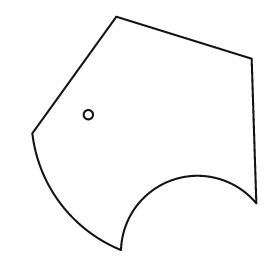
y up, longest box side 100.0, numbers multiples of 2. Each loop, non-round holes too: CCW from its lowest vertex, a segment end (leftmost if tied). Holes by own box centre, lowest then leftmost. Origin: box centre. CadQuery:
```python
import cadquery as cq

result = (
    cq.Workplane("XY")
    .moveTo(-10.0, -50.0)
    .threePointArc((12.0, -20.0), (48.0, -30.0))
    .lineTo(46.0, 32.0)
    .lineTo(-12.0, 50.0)
    .lineTo(-48.0, 0.0)
    .threePointArc((-36.0, -30.0), (-10.0, -50.0))
    .close()
    .moveTo(-24.0, 8.0)
    .circle(2.0)
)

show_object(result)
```